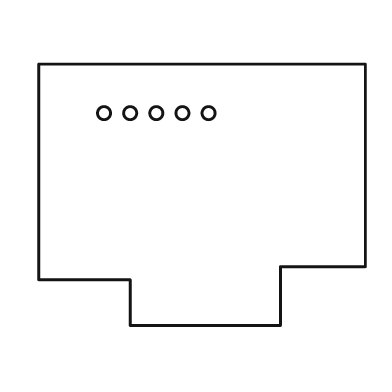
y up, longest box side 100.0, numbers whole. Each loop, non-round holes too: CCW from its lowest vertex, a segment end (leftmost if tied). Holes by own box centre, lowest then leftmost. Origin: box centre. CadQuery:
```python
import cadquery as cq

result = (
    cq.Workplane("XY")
    .moveTo(-22.0, -40.0)
    .lineTo(24.0, -40.0)
    .lineTo(24.0, -22.0)
    .lineTo(50.0, -22.0)
    .lineTo(50.0, 40.0)
    .lineTo(-50.0, 40.0)
    .lineTo(-50.0, -26.0)
    .lineTo(-22.0, -26.0)
    .close()
    .moveTo(-30.0, 25.0)
    .circle(2.0)
    .moveTo(-22.0, 25.0)
    .circle(2.0)
    .moveTo(-14.0, 25.0)
    .circle(2.0)
    .moveTo(-6.0, 25.0)
    .circle(2.0)
    .moveTo(2.0, 25.0)
    .circle(2.0)
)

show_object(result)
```